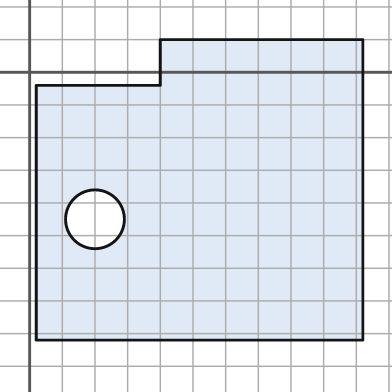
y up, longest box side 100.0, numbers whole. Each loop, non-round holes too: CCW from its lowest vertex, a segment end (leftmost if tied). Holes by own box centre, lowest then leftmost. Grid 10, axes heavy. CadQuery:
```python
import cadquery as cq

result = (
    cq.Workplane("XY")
    .moveTo(2.0, -82.0)
    .lineTo(102.0, -82.0)
    .lineTo(102.0, 10.0)
    .lineTo(40.0, 10.0)
    .lineTo(40.0, -4.0)
    .lineTo(2.0, -4.0)
    .close()
    .moveTo(20.0, -45.0)
    .circle(9.0)
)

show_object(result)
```